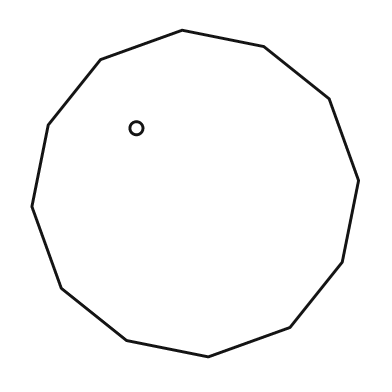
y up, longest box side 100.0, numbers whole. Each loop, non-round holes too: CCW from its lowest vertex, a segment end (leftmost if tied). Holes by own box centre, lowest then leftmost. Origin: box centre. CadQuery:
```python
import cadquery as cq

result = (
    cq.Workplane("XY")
    .moveTo(4.0, -50.0)
    .lineTo(29.0, -41.0)
    .lineTo(45.0, -21.0)
    .lineTo(50.0, 4.0)
    .lineTo(41.0, 29.0)
    .lineTo(21.0, 45.0)
    .lineTo(-4.0, 50.0)
    .lineTo(-29.0, 41.0)
    .lineTo(-45.0, 21.0)
    .lineTo(-50.0, -4.0)
    .lineTo(-41.0, -29.0)
    .lineTo(-21.0, -45.0)
    .close()
    .moveTo(-18.0, 20.0)
    .circle(2.0)
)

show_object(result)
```